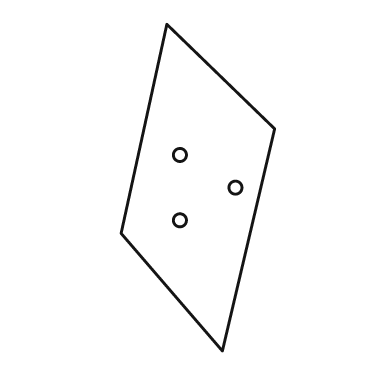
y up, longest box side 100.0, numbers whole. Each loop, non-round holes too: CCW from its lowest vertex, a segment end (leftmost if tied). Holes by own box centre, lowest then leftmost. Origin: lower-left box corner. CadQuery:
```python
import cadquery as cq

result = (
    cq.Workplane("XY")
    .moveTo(31.0, 0.0)
    .lineTo(47.0, 68.0)
    .lineTo(14.0, 100.0)
    .lineTo(0.0, 36.0)
    .close()
    .moveTo(18.0, 40.0)
    .circle(2.0)
    .moveTo(35.0, 50.0)
    .circle(2.0)
    .moveTo(18.0, 60.0)
    .circle(2.0)
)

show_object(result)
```